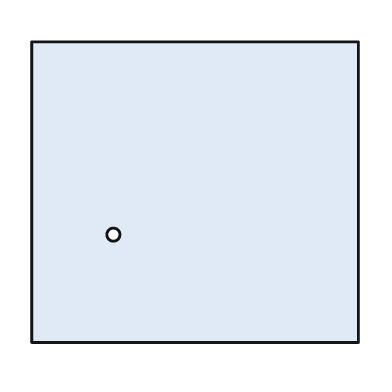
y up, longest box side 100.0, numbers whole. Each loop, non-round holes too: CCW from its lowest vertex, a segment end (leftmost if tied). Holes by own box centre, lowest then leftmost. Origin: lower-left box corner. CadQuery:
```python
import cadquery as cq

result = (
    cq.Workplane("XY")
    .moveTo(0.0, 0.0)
    .lineTo(100.0, 0.0)
    .lineTo(100.0, 92.0)
    .lineTo(0.0, 92.0)
    .close()
    .moveTo(25.0, 33.0)
    .circle(2.0)
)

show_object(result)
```